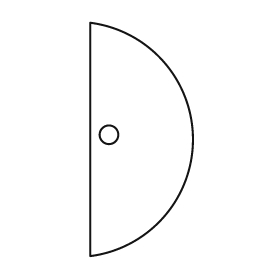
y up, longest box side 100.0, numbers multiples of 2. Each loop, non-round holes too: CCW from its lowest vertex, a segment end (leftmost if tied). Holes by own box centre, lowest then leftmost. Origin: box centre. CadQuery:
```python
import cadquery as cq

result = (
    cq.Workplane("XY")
    .moveTo(-22.0, -50.0)
    .threePointArc((22.0, 0.0), (-22.0, 50.0))
    .close()
    .moveTo(-14.0, 2.0)
    .circle(4.0)
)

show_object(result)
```